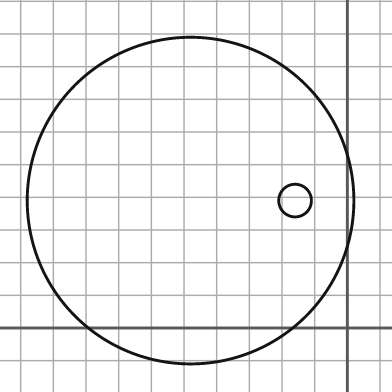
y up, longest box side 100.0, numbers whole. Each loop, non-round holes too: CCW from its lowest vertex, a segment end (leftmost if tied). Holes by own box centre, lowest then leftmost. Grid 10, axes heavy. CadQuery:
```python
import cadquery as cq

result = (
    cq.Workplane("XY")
    .moveTo(-48.0, 39.0)
    .circle(50.0)
    .moveTo(-16.0, 39.0)
    .circle(5.0)
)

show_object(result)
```